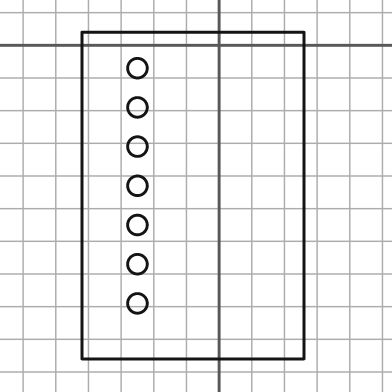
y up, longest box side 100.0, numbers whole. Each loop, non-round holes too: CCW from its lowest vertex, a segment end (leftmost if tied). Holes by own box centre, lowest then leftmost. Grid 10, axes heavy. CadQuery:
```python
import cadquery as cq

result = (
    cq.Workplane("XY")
    .moveTo(-42.0, -96.0)
    .lineTo(26.0, -96.0)
    .lineTo(26.0, 4.0)
    .lineTo(-42.0, 4.0)
    .close()
    .moveTo(-25.0, -79.0)
    .circle(3.0)
    .moveTo(-25.0, -67.0)
    .circle(3.0)
    .moveTo(-25.0, -55.0)
    .circle(3.0)
    .moveTo(-25.0, -43.0)
    .circle(3.0)
    .moveTo(-25.0, -31.0)
    .circle(3.0)
    .moveTo(-25.0, -19.0)
    .circle(3.0)
    .moveTo(-25.0, -7.0)
    .circle(3.0)
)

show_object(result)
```